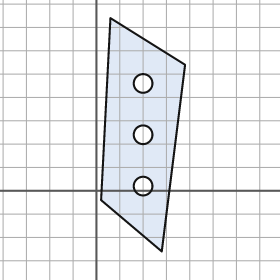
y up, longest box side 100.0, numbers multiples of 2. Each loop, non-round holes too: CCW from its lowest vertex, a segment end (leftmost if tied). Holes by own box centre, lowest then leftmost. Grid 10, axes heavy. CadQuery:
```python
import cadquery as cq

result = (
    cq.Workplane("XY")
    .moveTo(28.0, -26.0)
    .lineTo(38.0, 54.0)
    .lineTo(6.0, 74.0)
    .lineTo(2.0, -4.0)
    .close()
    .moveTo(20.0, 2.0)
    .circle(4.0)
    .moveTo(20.0, 24.0)
    .circle(4.0)
    .moveTo(20.0, 46.0)
    .circle(4.0)
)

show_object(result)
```